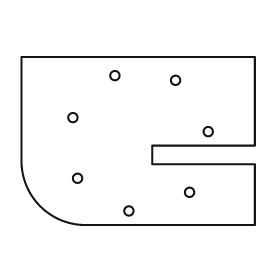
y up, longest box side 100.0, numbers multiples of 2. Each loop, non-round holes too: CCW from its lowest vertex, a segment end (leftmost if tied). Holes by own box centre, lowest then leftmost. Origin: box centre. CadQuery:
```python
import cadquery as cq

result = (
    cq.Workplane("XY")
    .moveTo(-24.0, -36.0)
    .lineTo(50.0, -36.0)
    .lineTo(50.0, -10.0)
    .lineTo(6.0, -10.0)
    .lineTo(6.0, -2.0)
    .lineTo(50.0, -2.0)
    .lineTo(50.0, 36.0)
    .lineTo(-50.0, 36.0)
    .lineTo(-50.0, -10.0)
    .threePointArc((-42.0, -28.0), (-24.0, -36.0))
    .close()
    .moveTo(-4.0, -30.0)
    .circle(2.0)
    .moveTo(22.0, -22.0)
    .circle(2.0)
    .moveTo(-26.0, -16.0)
    .circle(2.0)
    .moveTo(30.0, 4.0)
    .circle(2.0)
    .moveTo(-28.0, 10.0)
    .circle(2.0)
    .moveTo(16.0, 26.0)
    .circle(2.0)
    .moveTo(-10.0, 28.0)
    .circle(2.0)
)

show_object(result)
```